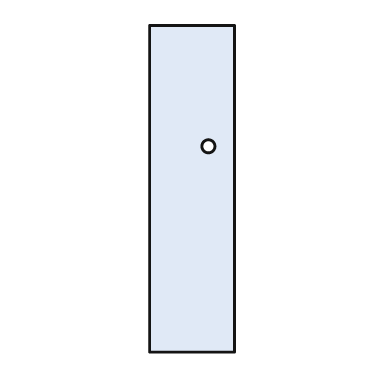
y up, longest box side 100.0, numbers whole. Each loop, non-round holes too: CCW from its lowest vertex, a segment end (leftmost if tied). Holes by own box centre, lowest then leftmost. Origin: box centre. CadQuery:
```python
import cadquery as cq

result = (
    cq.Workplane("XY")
    .moveTo(-13.0, -50.0)
    .lineTo(13.0, -50.0)
    .lineTo(13.0, 50.0)
    .lineTo(-13.0, 50.0)
    .close()
    .moveTo(5.0, 13.0)
    .circle(2.0)
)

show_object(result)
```